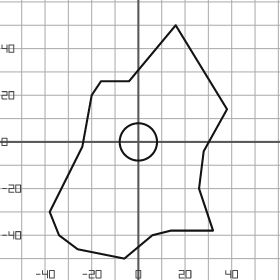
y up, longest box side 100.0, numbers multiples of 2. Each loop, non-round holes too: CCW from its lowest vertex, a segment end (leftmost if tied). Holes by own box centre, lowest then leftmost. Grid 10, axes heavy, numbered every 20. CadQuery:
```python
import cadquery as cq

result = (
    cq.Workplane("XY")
    .moveTo(-6.0, -50.0)
    .lineTo(6.0, -40.0)
    .lineTo(14.0, -38.0)
    .lineTo(32.0, -38.0)
    .lineTo(26.0, -20.0)
    .lineTo(28.0, -4.0)
    .lineTo(38.0, 14.0)
    .lineTo(16.0, 50.0)
    .lineTo(-4.0, 26.0)
    .lineTo(-16.0, 26.0)
    .lineTo(-20.0, 20.0)
    .lineTo(-24.0, -2.0)
    .lineTo(-38.0, -30.0)
    .lineTo(-34.0, -40.0)
    .lineTo(-26.0, -46.0)
    .close()
    .moveTo(0.0, 0.0)
    .circle(8.0)
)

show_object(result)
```